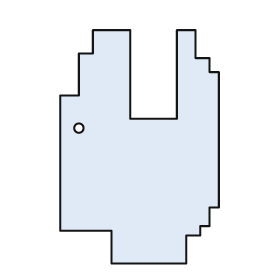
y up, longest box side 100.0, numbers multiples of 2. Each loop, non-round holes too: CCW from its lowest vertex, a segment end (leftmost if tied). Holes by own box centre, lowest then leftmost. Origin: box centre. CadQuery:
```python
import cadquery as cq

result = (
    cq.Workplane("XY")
    .moveTo(-12.0, -50.0)
    .lineTo(20.0, -50.0)
    .lineTo(20.0, -38.0)
    .lineTo(26.0, -38.0)
    .lineTo(26.0, -34.0)
    .lineTo(30.0, -34.0)
    .lineTo(30.0, -26.0)
    .lineTo(34.0, -26.0)
    .lineTo(34.0, 32.0)
    .lineTo(30.0, 32.0)
    .lineTo(30.0, 38.0)
    .lineTo(24.0, 38.0)
    .lineTo(24.0, 50.0)
    .lineTo(16.0, 50.0)
    .lineTo(16.0, 12.0)
    .lineTo(-4.0, 12.0)
    .lineTo(-4.0, 50.0)
    .lineTo(-20.0, 50.0)
    .lineTo(-20.0, 40.0)
    .lineTo(-26.0, 40.0)
    .lineTo(-26.0, 22.0)
    .lineTo(-34.0, 22.0)
    .lineTo(-34.0, -36.0)
    .lineTo(-12.0, -36.0)
    .close()
    .moveTo(-26.0, 8.0)
    .circle(2.0)
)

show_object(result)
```